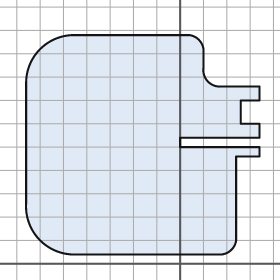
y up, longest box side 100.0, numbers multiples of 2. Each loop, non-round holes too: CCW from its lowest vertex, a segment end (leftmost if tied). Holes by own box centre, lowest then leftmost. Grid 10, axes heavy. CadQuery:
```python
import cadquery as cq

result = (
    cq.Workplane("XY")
    .moveTo(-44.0, 4.0)
    .lineTo(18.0, 4.0)
    .threePointArc((22.0, 6.0), (24.0, 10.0))
    .lineTo(24.0, 46.0)
    .lineTo(34.0, 46.0)
    .lineTo(34.0, 50.0)
    .lineTo(0.0, 50.0)
    .lineTo(0.0, 54.0)
    .lineTo(34.0, 54.0)
    .lineTo(34.0, 60.0)
    .lineTo(26.0, 60.0)
    .lineTo(26.0, 70.0)
    .lineTo(34.0, 70.0)
    .lineTo(34.0, 76.0)
    .lineTo(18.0, 76.0)
    .threePointArc((12.0, 78.0), (10.0, 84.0))
    .lineTo(10.0, 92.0)
    .threePointArc((8.0, 96.0), (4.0, 98.0))
    .lineTo(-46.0, 98.0)
    .threePointArc((-60.0, 92.0), (-66.0, 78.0))
    .lineTo(-66.0, 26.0)
    .threePointArc((-60.0, 10.0), (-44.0, 4.0))
    .close()
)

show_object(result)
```